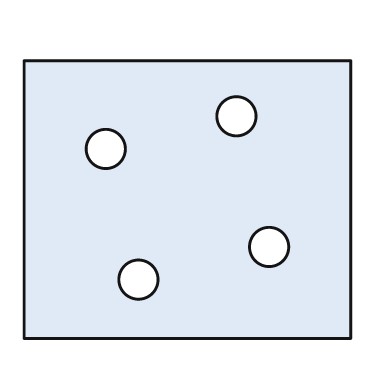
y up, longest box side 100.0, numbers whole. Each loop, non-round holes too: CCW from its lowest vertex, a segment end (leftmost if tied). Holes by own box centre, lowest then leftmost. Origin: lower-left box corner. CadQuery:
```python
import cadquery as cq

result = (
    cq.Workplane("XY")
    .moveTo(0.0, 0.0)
    .lineTo(100.0, 0.0)
    .lineTo(100.0, 85.0)
    .lineTo(0.0, 85.0)
    .close()
    .moveTo(35.0, 18.0)
    .circle(6.0)
    .moveTo(75.0, 28.0)
    .circle(6.0)
    .moveTo(25.0, 58.0)
    .circle(6.0)
    .moveTo(65.0, 68.0)
    .circle(6.0)
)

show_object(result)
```